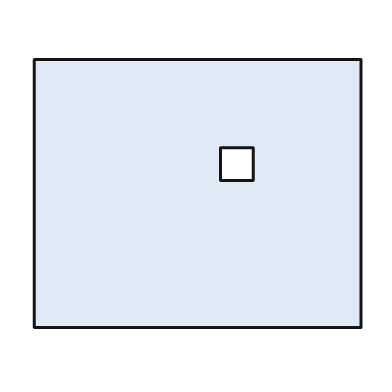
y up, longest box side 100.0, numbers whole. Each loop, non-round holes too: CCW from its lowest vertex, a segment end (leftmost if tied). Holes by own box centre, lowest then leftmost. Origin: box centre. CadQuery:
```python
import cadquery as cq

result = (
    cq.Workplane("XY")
    .moveTo(-50.0, -41.0)
    .lineTo(50.0, -41.0)
    .lineTo(50.0, 41.0)
    .lineTo(-50.0, 41.0)
    .close()
    .moveTo(7.0, 4.0)
    .lineTo(17.0, 4.0)
    .lineTo(17.0, 14.0)
    .lineTo(7.0, 14.0)
    .close()
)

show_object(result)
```